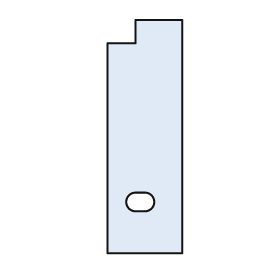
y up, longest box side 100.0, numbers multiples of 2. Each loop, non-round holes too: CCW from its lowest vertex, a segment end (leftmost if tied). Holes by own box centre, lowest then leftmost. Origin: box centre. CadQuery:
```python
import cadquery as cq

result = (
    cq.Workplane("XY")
    .moveTo(-16.0, -50.0)
    .lineTo(16.0, -50.0)
    .lineTo(16.0, 50.0)
    .lineTo(-4.0, 50.0)
    .lineTo(-4.0, 40.0)
    .lineTo(-16.0, 40.0)
    .close()
    .moveTo(-4.0, -32.0)
    .lineTo(0.0, -32.0)
    .threePointArc((4.0, -28.0), (0.0, -24.0))
    .lineTo(-4.0, -24.0)
    .threePointArc((-8.0, -28.0), (-4.0, -32.0))
    .close()
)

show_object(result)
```